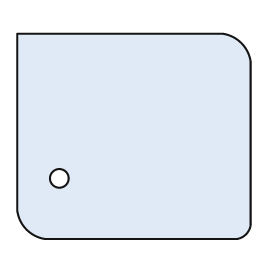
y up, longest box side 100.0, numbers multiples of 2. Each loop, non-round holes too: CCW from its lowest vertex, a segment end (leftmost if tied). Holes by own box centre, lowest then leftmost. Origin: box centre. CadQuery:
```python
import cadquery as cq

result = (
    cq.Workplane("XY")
    .moveTo(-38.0, -44.0)
    .lineTo(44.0, -44.0)
    .threePointArc((48.0, -42.0), (50.0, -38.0))
    .lineTo(50.0, 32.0)
    .threePointArc((46.0, 40.0), (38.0, 44.0))
    .lineTo(-50.0, 44.0)
    .lineTo(-50.0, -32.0)
    .threePointArc((-46.0, -40.0), (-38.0, -44.0))
    .close()
    .moveTo(-32.0, -18.0)
    .circle(4.0)
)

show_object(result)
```